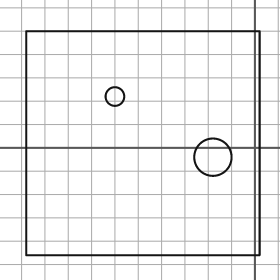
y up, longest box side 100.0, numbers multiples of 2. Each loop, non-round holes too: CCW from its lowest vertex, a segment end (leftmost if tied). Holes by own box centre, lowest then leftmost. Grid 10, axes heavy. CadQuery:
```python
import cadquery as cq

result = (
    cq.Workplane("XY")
    .moveTo(-98.0, -46.0)
    .lineTo(2.0, -46.0)
    .lineTo(2.0, 50.0)
    .lineTo(-98.0, 50.0)
    .close()
    .moveTo(-18.0, -4.0)
    .circle(8.0)
    .moveTo(-60.0, 22.0)
    .circle(4.0)
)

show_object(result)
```